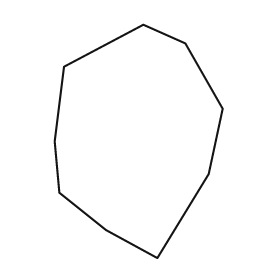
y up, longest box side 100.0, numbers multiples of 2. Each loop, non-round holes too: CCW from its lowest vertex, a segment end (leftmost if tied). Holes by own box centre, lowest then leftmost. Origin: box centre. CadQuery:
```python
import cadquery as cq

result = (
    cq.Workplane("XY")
    .moveTo(8.0, -50.0)
    .lineTo(30.0, -14.0)
    .lineTo(36.0, 14.0)
    .lineTo(20.0, 42.0)
    .lineTo(2.0, 50.0)
    .lineTo(-32.0, 32.0)
    .lineTo(-36.0, 0.0)
    .lineTo(-34.0, -22.0)
    .lineTo(-14.0, -38.0)
    .close()
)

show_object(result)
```